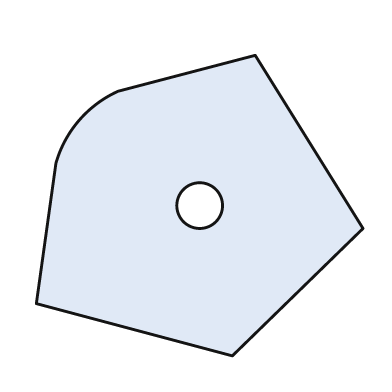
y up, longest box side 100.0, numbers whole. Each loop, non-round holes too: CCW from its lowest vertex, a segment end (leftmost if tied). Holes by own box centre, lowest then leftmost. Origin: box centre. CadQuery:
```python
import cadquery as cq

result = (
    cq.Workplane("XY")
    .moveTo(10.0, -46.0)
    .lineTo(50.0, -7.0)
    .lineTo(17.0, 46.0)
    .lineTo(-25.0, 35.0)
    .threePointArc((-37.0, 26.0), (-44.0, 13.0))
    .lineTo(-50.0, -30.0)
    .close()
    .moveTo(0.0, 0.0)
    .circle(7.0)
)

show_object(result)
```